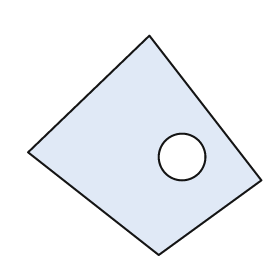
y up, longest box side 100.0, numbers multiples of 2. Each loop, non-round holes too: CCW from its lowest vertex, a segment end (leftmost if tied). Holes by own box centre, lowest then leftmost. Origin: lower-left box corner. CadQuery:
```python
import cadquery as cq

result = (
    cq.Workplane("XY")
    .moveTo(56.0, 0.0)
    .lineTo(100.0, 32.0)
    .lineTo(52.0, 94.0)
    .lineTo(0.0, 44.0)
    .close()
    .moveTo(66.0, 42.0)
    .circle(10.0)
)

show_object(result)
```